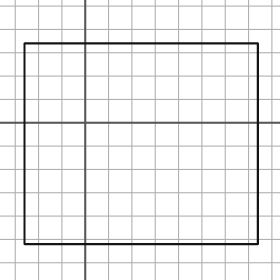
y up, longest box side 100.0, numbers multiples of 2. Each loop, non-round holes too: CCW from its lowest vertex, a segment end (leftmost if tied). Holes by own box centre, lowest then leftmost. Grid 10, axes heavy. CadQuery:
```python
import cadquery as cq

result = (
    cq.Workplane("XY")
    .moveTo(-26.0, -52.0)
    .lineTo(74.0, -52.0)
    .lineTo(74.0, 34.0)
    .lineTo(-26.0, 34.0)
    .close()
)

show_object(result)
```